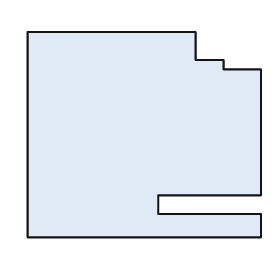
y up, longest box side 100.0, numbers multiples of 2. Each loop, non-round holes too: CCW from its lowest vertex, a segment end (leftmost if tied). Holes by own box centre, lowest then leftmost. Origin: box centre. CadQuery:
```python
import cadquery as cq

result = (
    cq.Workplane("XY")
    .moveTo(-50.0, -44.0)
    .lineTo(50.0, -44.0)
    .lineTo(50.0, -34.0)
    .lineTo(6.0, -34.0)
    .lineTo(6.0, -26.0)
    .lineTo(50.0, -26.0)
    .lineTo(50.0, 28.0)
    .lineTo(34.0, 28.0)
    .lineTo(34.0, 32.0)
    .lineTo(22.0, 32.0)
    .lineTo(22.0, 44.0)
    .lineTo(-50.0, 44.0)
    .close()
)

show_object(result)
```